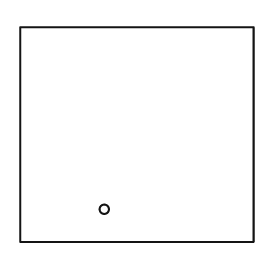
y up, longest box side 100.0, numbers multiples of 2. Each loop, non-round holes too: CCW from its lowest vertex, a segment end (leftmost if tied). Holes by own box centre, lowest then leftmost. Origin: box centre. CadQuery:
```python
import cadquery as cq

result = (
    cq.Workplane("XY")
    .moveTo(-50.0, -46.0)
    .lineTo(50.0, -46.0)
    .lineTo(50.0, 46.0)
    .lineTo(-50.0, 46.0)
    .close()
    .moveTo(-14.0, -32.0)
    .circle(2.0)
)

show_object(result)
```